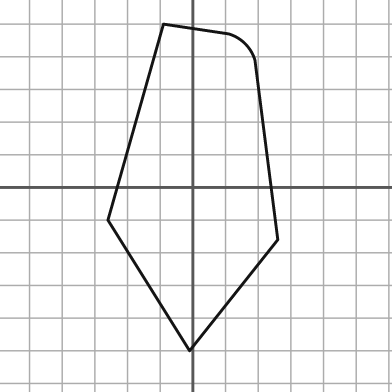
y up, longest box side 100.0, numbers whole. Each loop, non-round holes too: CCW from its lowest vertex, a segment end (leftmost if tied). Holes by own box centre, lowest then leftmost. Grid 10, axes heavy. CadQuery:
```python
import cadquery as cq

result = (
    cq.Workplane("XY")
    .moveTo(-1.0, -50.0)
    .lineTo(26.0, -16.0)
    .lineTo(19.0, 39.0)
    .threePointArc((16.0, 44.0), (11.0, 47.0))
    .lineTo(-9.0, 50.0)
    .lineTo(-26.0, -10.0)
    .close()
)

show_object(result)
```